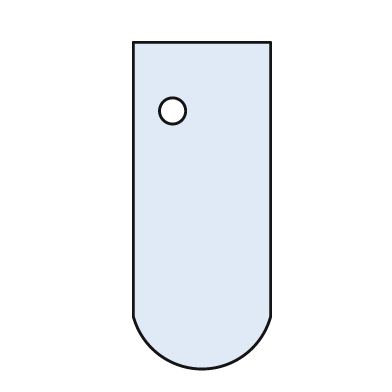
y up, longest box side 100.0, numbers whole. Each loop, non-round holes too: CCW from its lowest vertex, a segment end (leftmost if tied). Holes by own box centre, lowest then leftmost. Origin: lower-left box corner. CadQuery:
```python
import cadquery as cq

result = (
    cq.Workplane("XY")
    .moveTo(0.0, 16.0)
    .threePointArc((21.0, 0.0), (42.0, 16.0))
    .lineTo(42.0, 100.0)
    .lineTo(0.0, 100.0)
    .close()
    .moveTo(12.0, 79.0)
    .circle(4.0)
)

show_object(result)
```